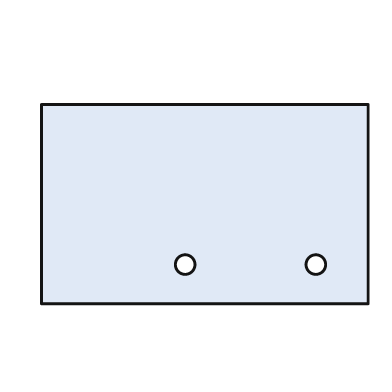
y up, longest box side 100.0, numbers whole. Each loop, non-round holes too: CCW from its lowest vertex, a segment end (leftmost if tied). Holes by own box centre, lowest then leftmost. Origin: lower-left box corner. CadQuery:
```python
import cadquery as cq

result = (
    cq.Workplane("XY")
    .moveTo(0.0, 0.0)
    .lineTo(100.0, 0.0)
    .lineTo(100.0, 61.0)
    .lineTo(0.0, 61.0)
    .close()
    .moveTo(44.0, 12.0)
    .circle(3.0)
    .moveTo(84.0, 12.0)
    .circle(3.0)
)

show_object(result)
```